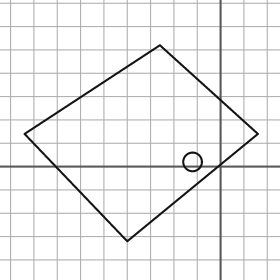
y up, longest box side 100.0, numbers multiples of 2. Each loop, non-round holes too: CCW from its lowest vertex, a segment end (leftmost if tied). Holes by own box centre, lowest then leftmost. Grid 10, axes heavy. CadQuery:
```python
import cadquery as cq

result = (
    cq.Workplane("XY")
    .moveTo(-40.0, -32.0)
    .lineTo(16.0, 14.0)
    .lineTo(-26.0, 52.0)
    .lineTo(-84.0, 14.0)
    .close()
    .moveTo(-12.0, 2.0)
    .circle(4.0)
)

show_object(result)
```